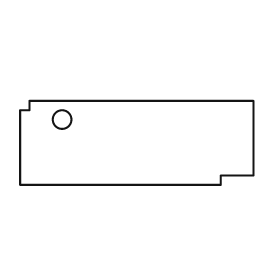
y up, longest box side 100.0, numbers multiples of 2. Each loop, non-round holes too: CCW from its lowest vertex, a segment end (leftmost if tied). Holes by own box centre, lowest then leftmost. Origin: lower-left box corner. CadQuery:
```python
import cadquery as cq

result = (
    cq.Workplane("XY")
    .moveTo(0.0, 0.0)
    .lineTo(86.0, 0.0)
    .lineTo(86.0, 4.0)
    .lineTo(100.0, 4.0)
    .lineTo(100.0, 36.0)
    .lineTo(4.0, 36.0)
    .lineTo(4.0, 32.0)
    .lineTo(0.0, 32.0)
    .close()
    .moveTo(18.0, 28.0)
    .circle(4.0)
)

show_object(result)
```